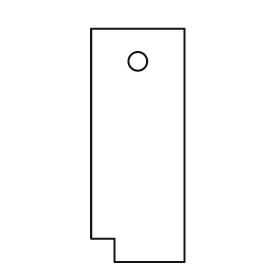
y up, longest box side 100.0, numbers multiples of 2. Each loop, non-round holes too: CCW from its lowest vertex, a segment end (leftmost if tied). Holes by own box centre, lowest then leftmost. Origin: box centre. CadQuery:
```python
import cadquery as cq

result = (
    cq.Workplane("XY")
    .moveTo(-10.0, -50.0)
    .lineTo(20.0, -50.0)
    .lineTo(20.0, 50.0)
    .lineTo(-20.0, 50.0)
    .lineTo(-20.0, -40.0)
    .lineTo(-10.0, -40.0)
    .close()
    .moveTo(0.0, 36.0)
    .circle(4.0)
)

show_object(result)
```